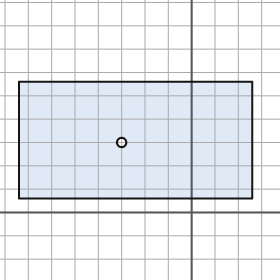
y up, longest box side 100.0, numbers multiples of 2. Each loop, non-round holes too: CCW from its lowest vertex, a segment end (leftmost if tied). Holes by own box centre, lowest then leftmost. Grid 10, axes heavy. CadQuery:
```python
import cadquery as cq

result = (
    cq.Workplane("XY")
    .moveTo(-74.0, 6.0)
    .lineTo(26.0, 6.0)
    .lineTo(26.0, 56.0)
    .lineTo(-74.0, 56.0)
    .close()
    .moveTo(-30.0, 30.0)
    .circle(2.0)
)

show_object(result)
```